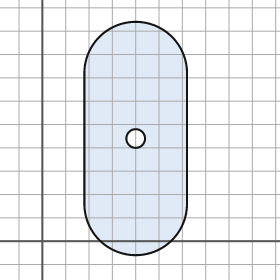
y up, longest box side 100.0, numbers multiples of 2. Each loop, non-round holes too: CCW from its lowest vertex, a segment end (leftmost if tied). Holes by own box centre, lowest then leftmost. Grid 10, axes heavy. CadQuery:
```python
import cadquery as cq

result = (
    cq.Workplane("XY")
    .moveTo(18.0, 16.0)
    .threePointArc((40.0, -6.0), (62.0, 16.0))
    .lineTo(62.0, 72.0)
    .threePointArc((40.0, 94.0), (18.0, 72.0))
    .close()
    .moveTo(40.0, 44.0)
    .circle(4.0)
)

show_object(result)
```